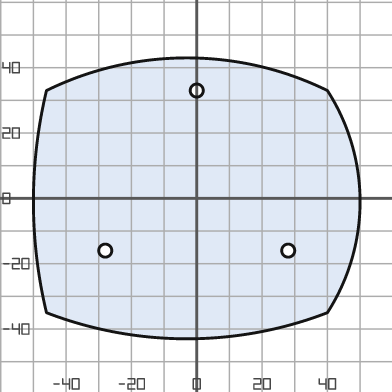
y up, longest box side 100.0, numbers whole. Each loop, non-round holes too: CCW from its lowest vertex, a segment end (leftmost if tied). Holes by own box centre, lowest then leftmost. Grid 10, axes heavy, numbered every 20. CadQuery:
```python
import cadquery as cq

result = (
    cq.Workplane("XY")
    .moveTo(-46.0, -35.0)
    .threePointArc((-3.0, -43.0), (40.0, -35.0))
    .threePointArc((50.0, -1.0), (40.0, 33.0))
    .threePointArc((-3.0, 43.0), (-46.0, 33.0))
    .threePointArc((-50.0, -1.0), (-46.0, -35.0))
    .close()
    .moveTo(-28.0, -16.0)
    .circle(2.0)
    .moveTo(28.0, -16.0)
    .circle(2.0)
    .moveTo(0.0, 33.0)
    .circle(2.0)
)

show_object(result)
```